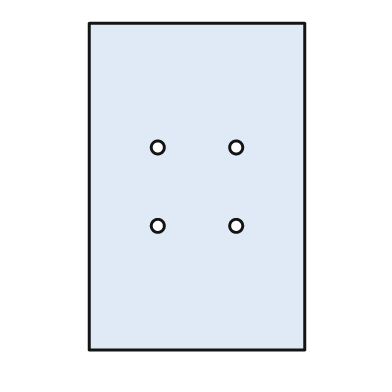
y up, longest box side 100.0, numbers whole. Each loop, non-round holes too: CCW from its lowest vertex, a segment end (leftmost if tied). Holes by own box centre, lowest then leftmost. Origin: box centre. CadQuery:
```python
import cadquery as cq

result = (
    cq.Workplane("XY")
    .moveTo(-33.0, -50.0)
    .lineTo(33.0, -50.0)
    .lineTo(33.0, 50.0)
    .lineTo(-33.0, 50.0)
    .close()
    .moveTo(-12.0, -12.0)
    .circle(2.0)
    .moveTo(12.0, -12.0)
    .circle(2.0)
    .moveTo(-12.0, 12.0)
    .circle(2.0)
    .moveTo(12.0, 12.0)
    .circle(2.0)
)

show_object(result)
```